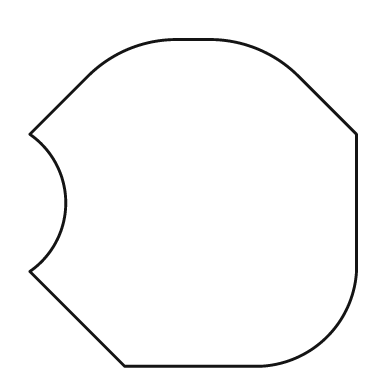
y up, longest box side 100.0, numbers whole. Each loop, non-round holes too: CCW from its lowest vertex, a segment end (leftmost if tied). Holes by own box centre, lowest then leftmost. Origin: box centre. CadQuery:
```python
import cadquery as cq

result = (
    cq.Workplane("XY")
    .moveTo(-21.0, -50.0)
    .lineTo(21.0, -50.0)
    .threePointArc((41.0, -41.0), (50.0, -21.0))
    .lineTo(50.0, 21.0)
    .lineTo(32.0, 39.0)
    .threePointArc((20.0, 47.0), (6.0, 50.0))
    .lineTo(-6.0, 50.0)
    .threePointArc((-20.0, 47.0), (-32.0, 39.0))
    .lineTo(-50.0, 21.0)
    .threePointArc((-39.0, 0.0), (-50.0, -21.0))
    .close()
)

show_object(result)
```